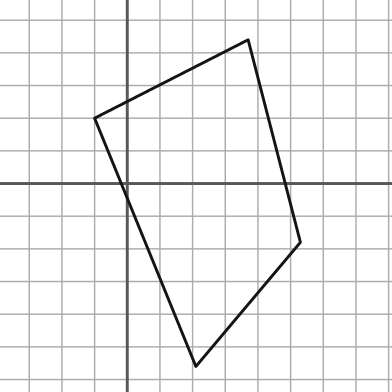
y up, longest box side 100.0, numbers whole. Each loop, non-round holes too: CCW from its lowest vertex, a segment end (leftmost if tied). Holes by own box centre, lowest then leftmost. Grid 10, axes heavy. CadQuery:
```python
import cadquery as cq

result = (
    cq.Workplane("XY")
    .moveTo(21.0, -56.0)
    .lineTo(53.0, -18.0)
    .lineTo(37.0, 44.0)
    .lineTo(-10.0, 20.0)
    .close()
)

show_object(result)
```